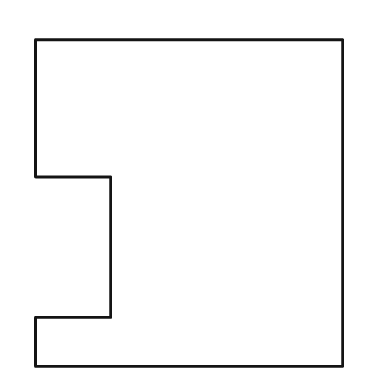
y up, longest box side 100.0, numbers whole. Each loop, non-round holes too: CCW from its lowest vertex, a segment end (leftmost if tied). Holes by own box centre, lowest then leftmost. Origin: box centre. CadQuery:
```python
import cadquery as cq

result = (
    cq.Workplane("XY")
    .moveTo(-47.0, -50.0)
    .lineTo(47.0, -50.0)
    .lineTo(47.0, 50.0)
    .lineTo(-47.0, 50.0)
    .lineTo(-47.0, 8.0)
    .lineTo(-24.0, 8.0)
    .lineTo(-24.0, -35.0)
    .lineTo(-47.0, -35.0)
    .close()
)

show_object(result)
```